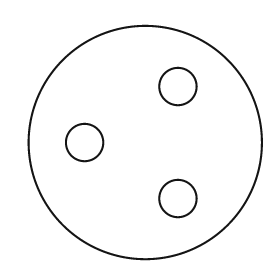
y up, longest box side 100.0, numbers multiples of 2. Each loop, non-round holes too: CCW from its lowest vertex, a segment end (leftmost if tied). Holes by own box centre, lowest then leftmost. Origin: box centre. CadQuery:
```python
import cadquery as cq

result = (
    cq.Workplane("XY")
    .moveTo(0.0, 0.0)
    .circle(50.0)
    .moveTo(14.0, -24.0)
    .circle(8.0)
    .moveTo(-26.0, 0.0)
    .circle(8.0)
    .moveTo(14.0, 24.0)
    .circle(8.0)
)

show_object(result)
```